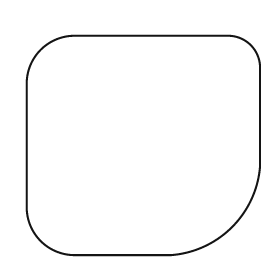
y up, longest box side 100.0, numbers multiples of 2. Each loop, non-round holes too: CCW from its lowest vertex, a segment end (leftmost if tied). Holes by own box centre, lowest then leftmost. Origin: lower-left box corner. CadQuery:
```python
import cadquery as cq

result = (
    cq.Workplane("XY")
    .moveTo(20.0, 0.0)
    .lineTo(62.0, 0.0)
    .threePointArc((88.0, 12.0), (100.0, 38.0))
    .lineTo(100.0, 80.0)
    .threePointArc((96.0, 90.0), (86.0, 94.0))
    .lineTo(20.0, 94.0)
    .threePointArc((6.0, 88.0), (0.0, 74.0))
    .lineTo(0.0, 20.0)
    .threePointArc((6.0, 6.0), (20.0, 0.0))
    .close()
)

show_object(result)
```